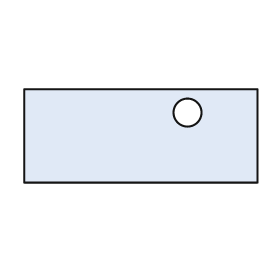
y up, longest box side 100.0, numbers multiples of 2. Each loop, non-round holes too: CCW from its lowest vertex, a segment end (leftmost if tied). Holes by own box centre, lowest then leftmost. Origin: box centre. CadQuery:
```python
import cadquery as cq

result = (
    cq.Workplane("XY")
    .moveTo(-50.0, -20.0)
    .lineTo(50.0, -20.0)
    .lineTo(50.0, 20.0)
    .lineTo(-50.0, 20.0)
    .close()
    .moveTo(20.0, 10.0)
    .circle(6.0)
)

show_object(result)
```